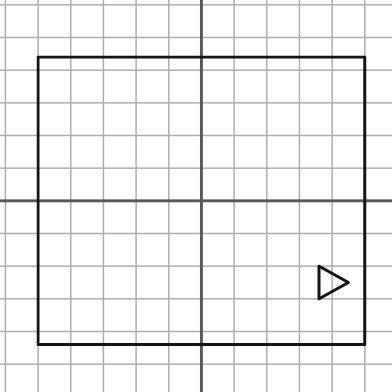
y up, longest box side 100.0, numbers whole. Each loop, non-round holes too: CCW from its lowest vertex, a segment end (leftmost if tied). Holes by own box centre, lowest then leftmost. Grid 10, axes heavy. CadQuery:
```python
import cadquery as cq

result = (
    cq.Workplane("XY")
    .moveTo(-50.0, -44.0)
    .lineTo(50.0, -44.0)
    .lineTo(50.0, 44.0)
    .lineTo(-50.0, 44.0)
    .close()
    .moveTo(36.0, -30.0)
    .lineTo(45.0, -25.0)
    .lineTo(36.0, -20.0)
    .close()
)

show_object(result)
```